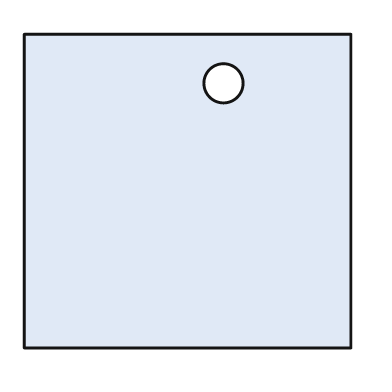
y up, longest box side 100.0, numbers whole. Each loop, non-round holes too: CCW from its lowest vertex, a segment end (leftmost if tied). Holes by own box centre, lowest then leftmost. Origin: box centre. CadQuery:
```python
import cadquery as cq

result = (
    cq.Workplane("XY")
    .moveTo(-50.0, -48.0)
    .lineTo(50.0, -48.0)
    .lineTo(50.0, 48.0)
    .lineTo(-50.0, 48.0)
    .close()
    .moveTo(11.0, 33.0)
    .circle(6.0)
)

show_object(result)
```